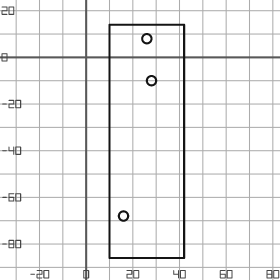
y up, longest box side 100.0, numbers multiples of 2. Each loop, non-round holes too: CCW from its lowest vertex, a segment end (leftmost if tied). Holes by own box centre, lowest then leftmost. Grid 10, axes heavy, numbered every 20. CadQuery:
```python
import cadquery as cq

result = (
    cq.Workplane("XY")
    .moveTo(10.0, -86.0)
    .lineTo(42.0, -86.0)
    .lineTo(42.0, 14.0)
    .lineTo(10.0, 14.0)
    .close()
    .moveTo(16.0, -68.0)
    .circle(2.0)
    .moveTo(28.0, -10.0)
    .circle(2.0)
    .moveTo(26.0, 8.0)
    .circle(2.0)
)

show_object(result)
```